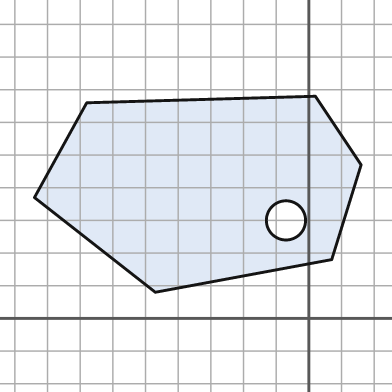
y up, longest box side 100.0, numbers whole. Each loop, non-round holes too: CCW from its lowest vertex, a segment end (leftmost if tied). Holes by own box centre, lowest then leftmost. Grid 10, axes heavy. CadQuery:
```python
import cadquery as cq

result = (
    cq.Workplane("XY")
    .moveTo(-47.0, 8.0)
    .lineTo(7.0, 18.0)
    .lineTo(16.0, 47.0)
    .lineTo(2.0, 68.0)
    .lineTo(-68.0, 66.0)
    .lineTo(-84.0, 37.0)
    .close()
    .moveTo(-7.0, 30.0)
    .circle(6.0)
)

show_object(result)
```